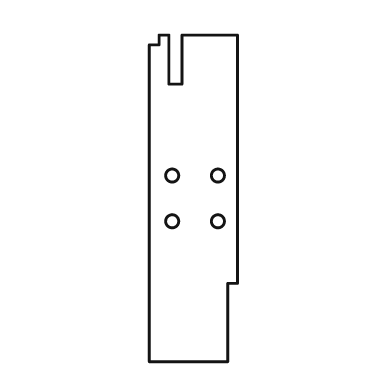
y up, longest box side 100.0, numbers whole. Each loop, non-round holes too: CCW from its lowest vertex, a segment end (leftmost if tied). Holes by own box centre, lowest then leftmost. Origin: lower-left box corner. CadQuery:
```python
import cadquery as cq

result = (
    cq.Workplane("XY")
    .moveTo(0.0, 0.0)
    .lineTo(24.0, 0.0)
    .lineTo(24.0, 24.0)
    .lineTo(27.0, 24.0)
    .lineTo(27.0, 100.0)
    .lineTo(10.0, 100.0)
    .lineTo(10.0, 85.0)
    .lineTo(6.0, 85.0)
    .lineTo(6.0, 100.0)
    .lineTo(3.0, 100.0)
    .lineTo(3.0, 97.0)
    .lineTo(0.0, 97.0)
    .close()
    .moveTo(7.0, 43.0)
    .circle(2.0)
    .moveTo(21.0, 43.0)
    .circle(2.0)
    .moveTo(7.0, 57.0)
    .circle(2.0)
    .moveTo(21.0, 57.0)
    .circle(2.0)
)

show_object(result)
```